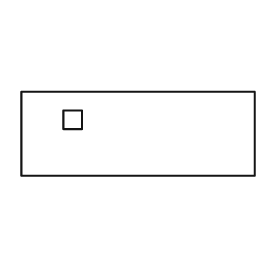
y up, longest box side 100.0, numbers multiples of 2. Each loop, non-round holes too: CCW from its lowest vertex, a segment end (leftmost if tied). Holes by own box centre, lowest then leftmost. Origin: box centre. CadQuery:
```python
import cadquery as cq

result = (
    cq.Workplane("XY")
    .moveTo(-50.0, -18.0)
    .lineTo(50.0, -18.0)
    .lineTo(50.0, 18.0)
    .lineTo(-50.0, 18.0)
    .close()
    .moveTo(-32.0, 2.0)
    .lineTo(-24.0, 2.0)
    .lineTo(-24.0, 10.0)
    .lineTo(-32.0, 10.0)
    .close()
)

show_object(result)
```